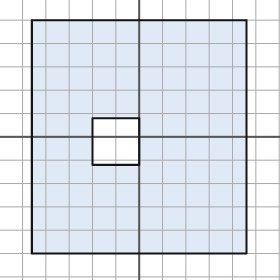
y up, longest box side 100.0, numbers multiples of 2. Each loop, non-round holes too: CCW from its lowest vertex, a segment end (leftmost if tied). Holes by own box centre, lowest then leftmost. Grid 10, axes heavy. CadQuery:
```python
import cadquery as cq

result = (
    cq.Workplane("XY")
    .moveTo(-46.0, -50.0)
    .lineTo(46.0, -50.0)
    .lineTo(46.0, 50.0)
    .lineTo(-46.0, 50.0)
    .close()
    .moveTo(-20.0, -12.0)
    .lineTo(0.0, -12.0)
    .lineTo(0.0, 8.0)
    .lineTo(-20.0, 8.0)
    .close()
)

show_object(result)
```